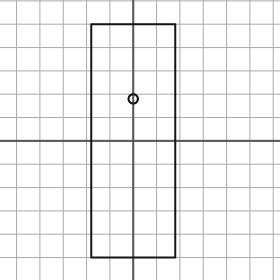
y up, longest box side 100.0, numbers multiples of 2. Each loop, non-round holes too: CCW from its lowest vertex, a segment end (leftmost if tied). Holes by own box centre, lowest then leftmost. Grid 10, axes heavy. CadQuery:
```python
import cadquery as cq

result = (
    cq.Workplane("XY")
    .moveTo(-18.0, -50.0)
    .lineTo(18.0, -50.0)
    .lineTo(18.0, 50.0)
    .lineTo(-18.0, 50.0)
    .close()
    .moveTo(0.0, 18.0)
    .circle(2.0)
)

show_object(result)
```